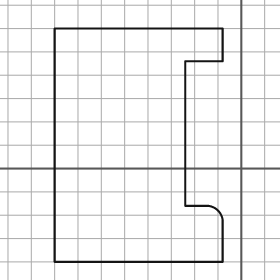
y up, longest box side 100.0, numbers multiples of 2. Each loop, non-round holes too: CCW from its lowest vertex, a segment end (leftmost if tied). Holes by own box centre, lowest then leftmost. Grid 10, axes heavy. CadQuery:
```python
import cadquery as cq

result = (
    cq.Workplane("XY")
    .moveTo(-80.0, -40.0)
    .lineTo(-8.0, -40.0)
    .lineTo(-8.0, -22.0)
    .threePointArc((-10.0, -18.0), (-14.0, -16.0))
    .lineTo(-24.0, -16.0)
    .lineTo(-24.0, 46.0)
    .lineTo(-8.0, 46.0)
    .lineTo(-8.0, 60.0)
    .lineTo(-80.0, 60.0)
    .close()
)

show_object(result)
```